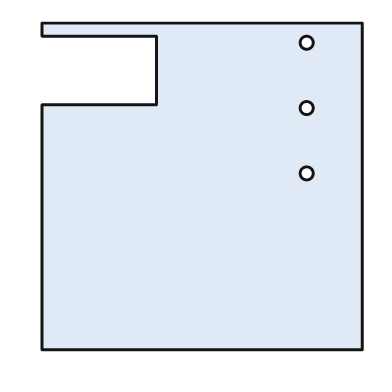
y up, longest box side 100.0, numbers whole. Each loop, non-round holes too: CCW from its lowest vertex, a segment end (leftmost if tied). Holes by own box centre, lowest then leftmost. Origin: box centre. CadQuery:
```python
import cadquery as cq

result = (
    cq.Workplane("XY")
    .moveTo(-49.0, -50.0)
    .lineTo(49.0, -50.0)
    .lineTo(49.0, 50.0)
    .lineTo(-49.0, 50.0)
    .lineTo(-49.0, 46.0)
    .lineTo(-14.0, 46.0)
    .lineTo(-14.0, 25.0)
    .lineTo(-49.0, 25.0)
    .close()
    .moveTo(32.0, 4.0)
    .circle(2.0)
    .moveTo(32.0, 24.0)
    .circle(2.0)
    .moveTo(32.0, 44.0)
    .circle(2.0)
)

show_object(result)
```